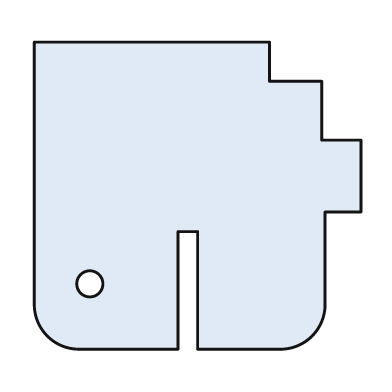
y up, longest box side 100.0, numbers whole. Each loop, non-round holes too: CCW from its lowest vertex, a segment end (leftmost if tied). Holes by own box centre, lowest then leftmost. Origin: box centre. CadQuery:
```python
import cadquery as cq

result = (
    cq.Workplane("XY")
    .moveTo(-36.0, -47.0)
    .lineTo(-6.0, -47.0)
    .lineTo(-6.0, -11.0)
    .lineTo(0.0, -11.0)
    .lineTo(0.0, -47.0)
    .lineTo(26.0, -47.0)
    .threePointArc((35.0, -43.0), (39.0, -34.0))
    .lineTo(39.0, -5.0)
    .lineTo(50.0, -5.0)
    .lineTo(50.0, 17.0)
    .lineTo(38.0, 17.0)
    .lineTo(38.0, 35.0)
    .lineTo(22.0, 35.0)
    .lineTo(22.0, 47.0)
    .lineTo(-50.0, 47.0)
    .lineTo(-50.0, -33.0)
    .threePointArc((-46.0, -43.0), (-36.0, -47.0))
    .close()
    .moveTo(-33.0, -27.0)
    .circle(4.0)
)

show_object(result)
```